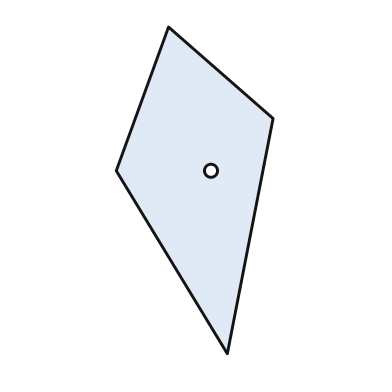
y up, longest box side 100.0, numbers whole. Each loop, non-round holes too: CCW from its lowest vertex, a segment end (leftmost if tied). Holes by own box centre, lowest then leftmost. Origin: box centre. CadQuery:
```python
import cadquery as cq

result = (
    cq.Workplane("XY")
    .moveTo(10.0, -50.0)
    .lineTo(24.0, 22.0)
    .lineTo(-8.0, 50.0)
    .lineTo(-24.0, 6.0)
    .close()
    .moveTo(5.0, 6.0)
    .circle(2.0)
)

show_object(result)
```